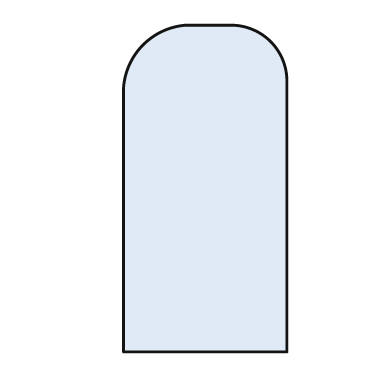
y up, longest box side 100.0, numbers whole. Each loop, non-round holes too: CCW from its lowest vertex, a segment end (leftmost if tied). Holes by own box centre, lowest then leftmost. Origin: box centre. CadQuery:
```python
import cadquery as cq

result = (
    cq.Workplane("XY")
    .moveTo(-25.0, -50.0)
    .lineTo(25.0, -50.0)
    .lineTo(25.0, 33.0)
    .threePointArc((20.0, 45.0), (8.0, 50.0))
    .lineTo(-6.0, 50.0)
    .threePointArc((-19.0, 44.0), (-25.0, 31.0))
    .close()
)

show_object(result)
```